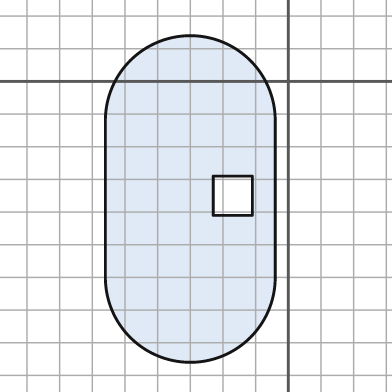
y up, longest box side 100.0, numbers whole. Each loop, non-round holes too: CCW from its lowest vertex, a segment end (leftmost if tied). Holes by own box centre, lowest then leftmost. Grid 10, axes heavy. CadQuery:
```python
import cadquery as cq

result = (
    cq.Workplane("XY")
    .moveTo(-56.0, -60.0)
    .threePointArc((-30.0, -86.0), (-4.0, -60.0))
    .lineTo(-4.0, -12.0)
    .threePointArc((-30.0, 14.0), (-56.0, -12.0))
    .close()
    .moveTo(-23.0, -41.0)
    .lineTo(-11.0, -41.0)
    .lineTo(-11.0, -29.0)
    .lineTo(-23.0, -29.0)
    .close()
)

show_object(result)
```